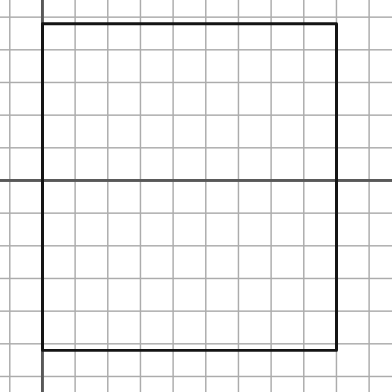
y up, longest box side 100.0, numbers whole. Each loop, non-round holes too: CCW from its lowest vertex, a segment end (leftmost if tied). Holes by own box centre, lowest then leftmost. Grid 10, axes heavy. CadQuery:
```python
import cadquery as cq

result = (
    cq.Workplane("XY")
    .moveTo(0.0, -52.0)
    .lineTo(90.0, -52.0)
    .lineTo(90.0, 48.0)
    .lineTo(0.0, 48.0)
    .close()
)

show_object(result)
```